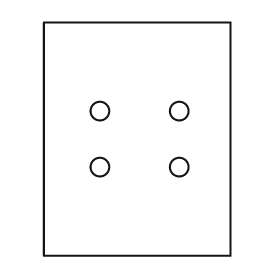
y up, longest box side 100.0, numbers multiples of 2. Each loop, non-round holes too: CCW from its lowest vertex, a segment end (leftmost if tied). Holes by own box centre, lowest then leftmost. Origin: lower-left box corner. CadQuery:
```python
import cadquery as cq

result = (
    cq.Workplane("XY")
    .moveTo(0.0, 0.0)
    .lineTo(80.0, 0.0)
    .lineTo(80.0, 100.0)
    .lineTo(0.0, 100.0)
    .close()
    .moveTo(24.0, 38.0)
    .circle(4.0)
    .moveTo(58.0, 38.0)
    .circle(4.0)
    .moveTo(24.0, 62.0)
    .circle(4.0)
    .moveTo(58.0, 62.0)
    .circle(4.0)
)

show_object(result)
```